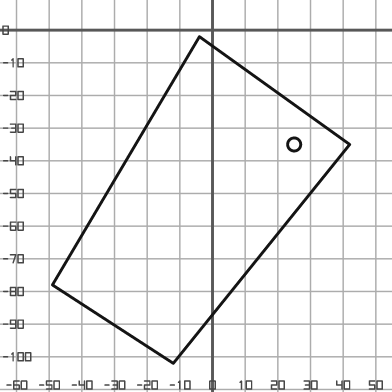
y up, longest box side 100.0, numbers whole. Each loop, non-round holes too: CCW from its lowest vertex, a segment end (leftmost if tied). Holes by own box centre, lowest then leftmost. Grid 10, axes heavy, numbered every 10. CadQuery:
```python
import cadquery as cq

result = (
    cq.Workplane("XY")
    .moveTo(-12.0, -102.0)
    .lineTo(42.0, -35.0)
    .lineTo(-4.0, -2.0)
    .lineTo(-49.0, -78.0)
    .close()
    .moveTo(25.0, -35.0)
    .circle(2.0)
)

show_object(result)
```